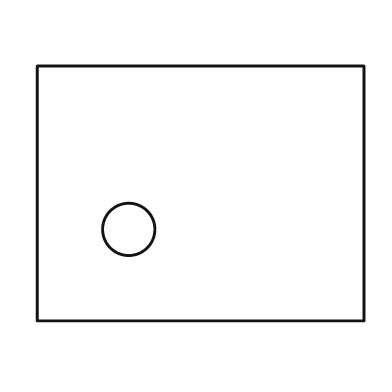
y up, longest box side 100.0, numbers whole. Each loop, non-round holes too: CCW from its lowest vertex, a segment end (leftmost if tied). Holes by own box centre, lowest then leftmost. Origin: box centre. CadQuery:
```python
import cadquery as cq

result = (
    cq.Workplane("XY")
    .moveTo(-50.0, -39.0)
    .lineTo(50.0, -39.0)
    .lineTo(50.0, 39.0)
    .lineTo(-50.0, 39.0)
    .close()
    .moveTo(-22.0, -11.0)
    .circle(8.0)
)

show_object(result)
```